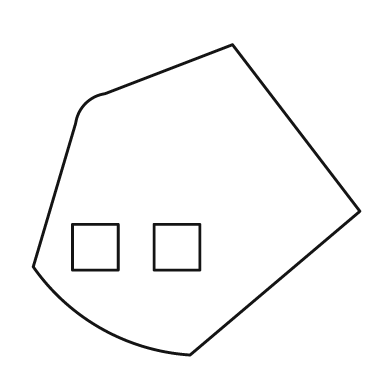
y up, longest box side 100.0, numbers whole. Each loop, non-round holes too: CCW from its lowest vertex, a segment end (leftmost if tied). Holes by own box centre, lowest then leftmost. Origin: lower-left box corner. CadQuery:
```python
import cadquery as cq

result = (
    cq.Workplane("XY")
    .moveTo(48.0, 0.0)
    .lineTo(100.0, 44.0)
    .lineTo(61.0, 95.0)
    .lineTo(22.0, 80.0)
    .threePointArc((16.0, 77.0), (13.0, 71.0))
    .lineTo(0.0, 27.0)
    .threePointArc((21.0, 8.0), (48.0, 0.0))
    .close()
    .moveTo(12.0, 26.0)
    .lineTo(26.0, 26.0)
    .lineTo(26.0, 40.0)
    .lineTo(12.0, 40.0)
    .close()
    .moveTo(37.0, 26.0)
    .lineTo(51.0, 26.0)
    .lineTo(51.0, 40.0)
    .lineTo(37.0, 40.0)
    .close()
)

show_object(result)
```